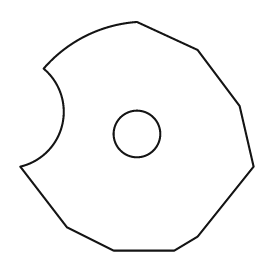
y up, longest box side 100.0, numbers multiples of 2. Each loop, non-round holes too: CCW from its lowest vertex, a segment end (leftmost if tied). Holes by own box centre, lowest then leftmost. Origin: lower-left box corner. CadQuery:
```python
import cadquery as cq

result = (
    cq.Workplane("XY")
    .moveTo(40.0, 0.0)
    .lineTo(66.0, 0.0)
    .lineTo(76.0, 6.0)
    .lineTo(100.0, 36.0)
    .lineTo(94.0, 62.0)
    .lineTo(76.0, 86.0)
    .lineTo(50.0, 98.0)
    .threePointArc((28.0, 92.0), (10.0, 78.0))
    .threePointArc((18.0, 54.0), (0.0, 36.0))
    .lineTo(20.0, 10.0)
    .close()
    .moveTo(50.0, 50.0)
    .circle(10.0)
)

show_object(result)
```